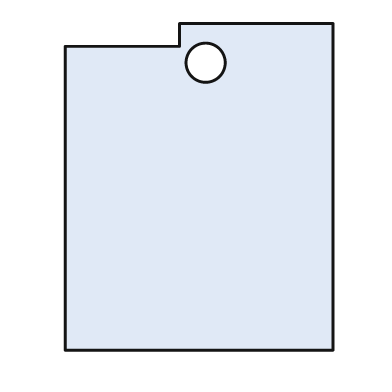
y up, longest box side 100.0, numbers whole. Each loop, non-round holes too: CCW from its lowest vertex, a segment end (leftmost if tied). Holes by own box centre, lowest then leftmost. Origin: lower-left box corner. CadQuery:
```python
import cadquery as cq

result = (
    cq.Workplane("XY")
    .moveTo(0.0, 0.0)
    .lineTo(82.0, 0.0)
    .lineTo(82.0, 100.0)
    .lineTo(35.0, 100.0)
    .lineTo(35.0, 93.0)
    .lineTo(0.0, 93.0)
    .close()
    .moveTo(43.0, 88.0)
    .circle(6.0)
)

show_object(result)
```